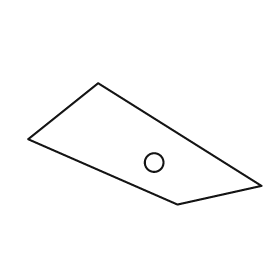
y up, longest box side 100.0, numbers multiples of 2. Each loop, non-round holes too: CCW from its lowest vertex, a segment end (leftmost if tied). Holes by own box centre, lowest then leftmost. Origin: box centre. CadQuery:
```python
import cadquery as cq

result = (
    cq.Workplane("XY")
    .moveTo(14.0, -26.0)
    .lineTo(50.0, -18.0)
    .lineTo(-20.0, 26.0)
    .lineTo(-50.0, 2.0)
    .close()
    .moveTo(4.0, -8.0)
    .circle(4.0)
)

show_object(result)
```